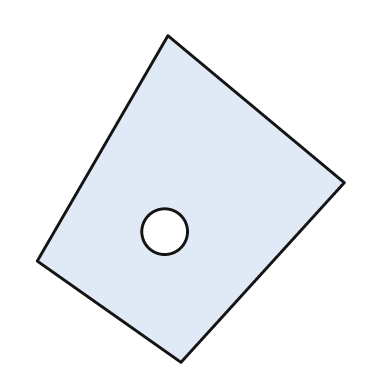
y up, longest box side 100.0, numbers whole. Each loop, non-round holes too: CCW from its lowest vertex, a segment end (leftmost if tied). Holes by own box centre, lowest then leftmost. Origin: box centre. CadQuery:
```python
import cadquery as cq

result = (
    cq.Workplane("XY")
    .moveTo(-3.0, -50.0)
    .lineTo(47.0, 5.0)
    .lineTo(-7.0, 50.0)
    .lineTo(-47.0, -19.0)
    .close()
    .moveTo(-8.0, -10.0)
    .circle(7.0)
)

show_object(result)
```